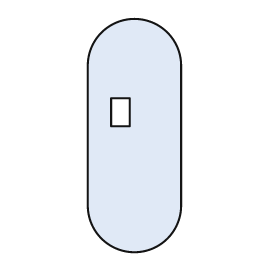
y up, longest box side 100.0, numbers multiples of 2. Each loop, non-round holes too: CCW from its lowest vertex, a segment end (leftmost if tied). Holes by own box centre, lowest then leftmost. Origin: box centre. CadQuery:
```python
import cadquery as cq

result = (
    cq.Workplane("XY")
    .moveTo(-20.0, -30.0)
    .threePointArc((0.0, -50.0), (20.0, -30.0))
    .lineTo(20.0, 30.0)
    .threePointArc((0.0, 50.0), (-20.0, 30.0))
    .close()
    .moveTo(-10.0, 4.0)
    .lineTo(-2.0, 4.0)
    .lineTo(-2.0, 16.0)
    .lineTo(-10.0, 16.0)
    .close()
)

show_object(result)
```